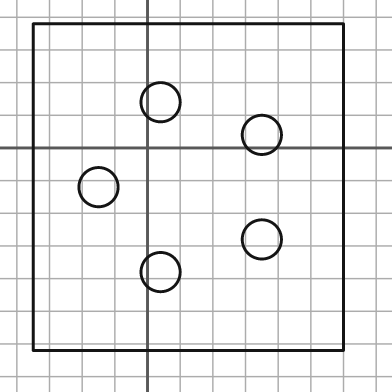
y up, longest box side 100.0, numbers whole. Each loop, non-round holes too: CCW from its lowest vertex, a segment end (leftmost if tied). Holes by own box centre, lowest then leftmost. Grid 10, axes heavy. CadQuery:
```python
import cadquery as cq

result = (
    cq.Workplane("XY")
    .moveTo(-35.0, -62.0)
    .lineTo(60.0, -62.0)
    .lineTo(60.0, 38.0)
    .lineTo(-35.0, 38.0)
    .close()
    .moveTo(4.0, -38.0)
    .circle(6.0)
    .moveTo(35.0, -28.0)
    .circle(6.0)
    .moveTo(-15.0, -12.0)
    .circle(6.0)
    .moveTo(35.0, 4.0)
    .circle(6.0)
    .moveTo(4.0, 14.0)
    .circle(6.0)
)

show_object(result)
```